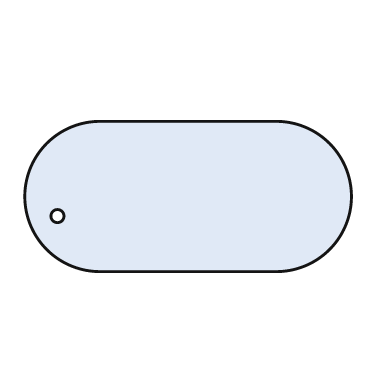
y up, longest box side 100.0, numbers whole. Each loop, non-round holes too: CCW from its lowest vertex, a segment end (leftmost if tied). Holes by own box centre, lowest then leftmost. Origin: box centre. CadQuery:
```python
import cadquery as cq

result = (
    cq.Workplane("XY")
    .moveTo(-27.0, -23.0)
    .lineTo(27.0, -23.0)
    .threePointArc((50.0, 0.0), (27.0, 23.0))
    .lineTo(-27.0, 23.0)
    .threePointArc((-50.0, 0.0), (-27.0, -23.0))
    .close()
    .moveTo(-40.0, -6.0)
    .circle(2.0)
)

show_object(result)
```